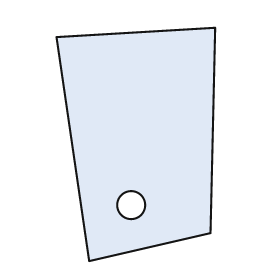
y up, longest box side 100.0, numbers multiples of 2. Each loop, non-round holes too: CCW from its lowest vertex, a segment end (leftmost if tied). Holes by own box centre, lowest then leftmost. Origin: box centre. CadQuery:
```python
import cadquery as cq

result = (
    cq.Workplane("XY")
    .moveTo(-20.0, -50.0)
    .lineTo(32.0, -38.0)
    .lineTo(34.0, 50.0)
    .lineTo(-34.0, 46.0)
    .close()
    .moveTo(-2.0, -26.0)
    .circle(6.0)
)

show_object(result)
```